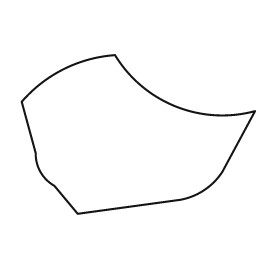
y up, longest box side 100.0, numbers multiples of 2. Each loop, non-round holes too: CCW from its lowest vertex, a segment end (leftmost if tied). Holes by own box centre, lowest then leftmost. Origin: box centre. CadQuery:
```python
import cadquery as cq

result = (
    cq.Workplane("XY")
    .moveTo(-26.0, -34.0)
    .lineTo(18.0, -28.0)
    .threePointArc((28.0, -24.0), (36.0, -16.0))
    .lineTo(50.0, 10.0)
    .threePointArc((16.0, 12.0), (-10.0, 34.0))
    .threePointArc((-32.0, 28.0), (-50.0, 14.0))
    .lineTo(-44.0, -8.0)
    .threePointArc((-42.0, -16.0), (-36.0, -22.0))
    .close()
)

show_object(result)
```